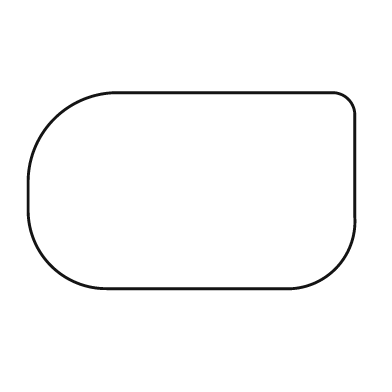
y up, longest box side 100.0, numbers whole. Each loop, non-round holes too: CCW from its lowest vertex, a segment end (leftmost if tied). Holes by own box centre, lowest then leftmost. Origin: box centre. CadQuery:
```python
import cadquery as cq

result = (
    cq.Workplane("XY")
    .moveTo(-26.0, -30.0)
    .lineTo(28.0, -30.0)
    .threePointArc((44.0, -24.0), (50.0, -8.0))
    .lineTo(50.0, 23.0)
    .threePointArc((48.0, 28.0), (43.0, 30.0))
    .lineTo(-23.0, 30.0)
    .threePointArc((-42.0, 22.0), (-50.0, 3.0))
    .lineTo(-50.0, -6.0)
    .threePointArc((-43.0, -23.0), (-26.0, -30.0))
    .close()
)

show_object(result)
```